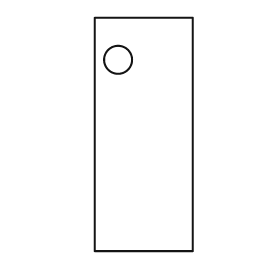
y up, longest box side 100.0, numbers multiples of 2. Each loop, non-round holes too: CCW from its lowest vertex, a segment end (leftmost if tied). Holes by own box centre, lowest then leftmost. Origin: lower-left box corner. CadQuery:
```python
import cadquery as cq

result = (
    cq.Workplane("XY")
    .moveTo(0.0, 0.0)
    .lineTo(42.0, 0.0)
    .lineTo(42.0, 100.0)
    .lineTo(0.0, 100.0)
    .close()
    .moveTo(10.0, 82.0)
    .circle(6.0)
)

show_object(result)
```